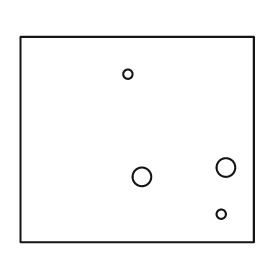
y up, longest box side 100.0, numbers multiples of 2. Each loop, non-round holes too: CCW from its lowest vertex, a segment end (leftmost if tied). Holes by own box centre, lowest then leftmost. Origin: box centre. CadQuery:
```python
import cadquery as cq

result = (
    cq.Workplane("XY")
    .moveTo(-50.0, -44.0)
    .lineTo(50.0, -44.0)
    .lineTo(50.0, 44.0)
    .lineTo(-50.0, 44.0)
    .close()
    .moveTo(36.0, -32.0)
    .circle(2.0)
    .moveTo(2.0, -16.0)
    .circle(4.0)
    .moveTo(38.0, -12.0)
    .circle(4.0)
    .moveTo(-4.0, 28.0)
    .circle(2.0)
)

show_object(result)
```